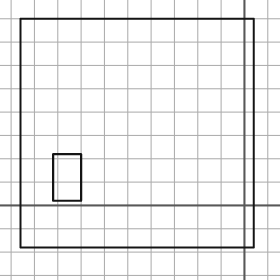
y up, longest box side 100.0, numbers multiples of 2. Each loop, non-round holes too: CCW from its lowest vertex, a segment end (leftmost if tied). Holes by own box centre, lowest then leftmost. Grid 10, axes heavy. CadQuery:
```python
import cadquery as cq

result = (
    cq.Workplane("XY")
    .moveTo(-96.0, -18.0)
    .lineTo(4.0, -18.0)
    .lineTo(4.0, 80.0)
    .lineTo(-96.0, 80.0)
    .close()
    .moveTo(-82.0, 2.0)
    .lineTo(-70.0, 2.0)
    .lineTo(-70.0, 22.0)
    .lineTo(-82.0, 22.0)
    .close()
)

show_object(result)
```